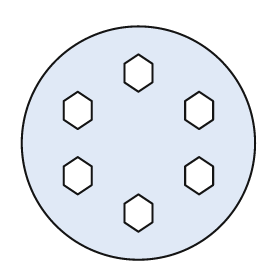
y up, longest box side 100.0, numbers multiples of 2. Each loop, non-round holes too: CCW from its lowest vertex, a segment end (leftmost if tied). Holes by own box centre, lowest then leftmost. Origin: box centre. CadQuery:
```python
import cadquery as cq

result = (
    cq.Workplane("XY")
    .moveTo(0.0, 0.0)
    .circle(50.0)
    .moveTo(0.0, -38.0)
    .lineTo(6.0, -34.0)
    .lineTo(6.0, -26.0)
    .lineTo(0.0, -22.0)
    .lineTo(-6.0, -26.0)
    .lineTo(-6.0, -34.0)
    .close()
    .moveTo(-26.0, -22.0)
    .lineTo(-20.0, -18.0)
    .lineTo(-20.0, -10.0)
    .lineTo(-26.0, -6.0)
    .lineTo(-32.0, -10.0)
    .lineTo(-32.0, -18.0)
    .close()
    .moveTo(26.0, -22.0)
    .lineTo(32.0, -18.0)
    .lineTo(32.0, -10.0)
    .lineTo(26.0, -6.0)
    .lineTo(20.0, -10.0)
    .lineTo(20.0, -18.0)
    .close()
    .moveTo(-26.0, 6.0)
    .lineTo(-20.0, 10.0)
    .lineTo(-20.0, 18.0)
    .lineTo(-26.0, 22.0)
    .lineTo(-32.0, 18.0)
    .lineTo(-32.0, 10.0)
    .close()
    .moveTo(26.0, 6.0)
    .lineTo(32.0, 10.0)
    .lineTo(32.0, 18.0)
    .lineTo(26.0, 22.0)
    .lineTo(20.0, 18.0)
    .lineTo(20.0, 10.0)
    .close()
    .moveTo(0.0, 22.0)
    .lineTo(6.0, 26.0)
    .lineTo(6.0, 34.0)
    .lineTo(0.0, 38.0)
    .lineTo(-6.0, 34.0)
    .lineTo(-6.0, 26.0)
    .close()
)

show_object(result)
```